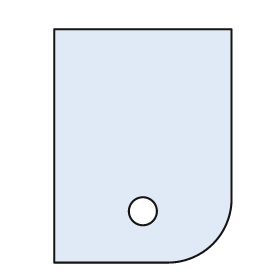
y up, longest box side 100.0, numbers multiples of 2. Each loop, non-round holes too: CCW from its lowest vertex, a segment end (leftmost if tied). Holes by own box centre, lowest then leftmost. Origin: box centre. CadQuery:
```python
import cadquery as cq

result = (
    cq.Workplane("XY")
    .moveTo(-38.0, -50.0)
    .lineTo(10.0, -50.0)
    .threePointArc((30.0, -42.0), (38.0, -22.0))
    .lineTo(38.0, 50.0)
    .lineTo(-38.0, 50.0)
    .close()
    .moveTo(0.0, -28.0)
    .circle(6.0)
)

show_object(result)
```